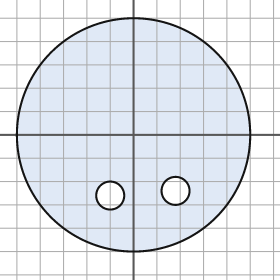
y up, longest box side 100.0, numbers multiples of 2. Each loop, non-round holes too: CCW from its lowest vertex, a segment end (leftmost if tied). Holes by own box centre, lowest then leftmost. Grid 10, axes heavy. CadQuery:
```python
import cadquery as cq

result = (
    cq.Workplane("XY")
    .moveTo(0.0, 0.0)
    .circle(50.0)
    .moveTo(-10.0, -26.0)
    .circle(6.0)
    .moveTo(18.0, -24.0)
    .circle(6.0)
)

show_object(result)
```